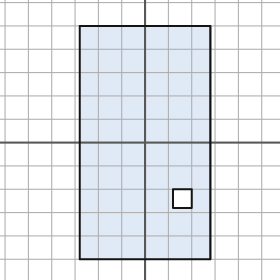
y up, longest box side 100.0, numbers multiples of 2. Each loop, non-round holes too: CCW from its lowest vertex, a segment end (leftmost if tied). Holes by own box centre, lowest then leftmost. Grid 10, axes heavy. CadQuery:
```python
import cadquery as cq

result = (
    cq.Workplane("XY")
    .moveTo(-28.0, -50.0)
    .lineTo(28.0, -50.0)
    .lineTo(28.0, 50.0)
    .lineTo(-28.0, 50.0)
    .close()
    .moveTo(12.0, -28.0)
    .lineTo(20.0, -28.0)
    .lineTo(20.0, -20.0)
    .lineTo(12.0, -20.0)
    .close()
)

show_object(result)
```